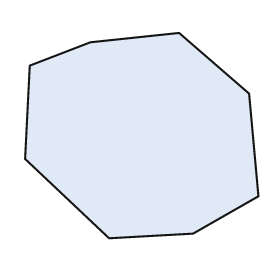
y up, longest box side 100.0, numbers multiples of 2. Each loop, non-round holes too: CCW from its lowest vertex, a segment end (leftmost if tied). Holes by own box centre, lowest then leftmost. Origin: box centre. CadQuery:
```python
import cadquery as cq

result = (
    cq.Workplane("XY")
    .moveTo(-14.0, -44.0)
    .lineTo(22.0, -42.0)
    .lineTo(50.0, -26.0)
    .lineTo(46.0, 18.0)
    .lineTo(16.0, 44.0)
    .lineTo(-22.0, 40.0)
    .lineTo(-48.0, 30.0)
    .lineTo(-50.0, -10.0)
    .close()
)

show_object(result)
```